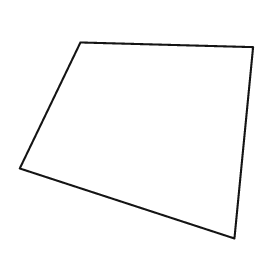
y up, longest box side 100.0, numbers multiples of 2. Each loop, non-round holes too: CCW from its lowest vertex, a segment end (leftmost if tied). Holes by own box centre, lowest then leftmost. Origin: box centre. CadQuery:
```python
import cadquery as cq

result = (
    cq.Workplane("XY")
    .moveTo(42.0, -42.0)
    .lineTo(50.0, 40.0)
    .lineTo(-24.0, 42.0)
    .lineTo(-50.0, -12.0)
    .close()
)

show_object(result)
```